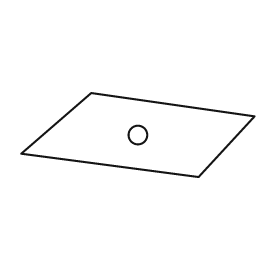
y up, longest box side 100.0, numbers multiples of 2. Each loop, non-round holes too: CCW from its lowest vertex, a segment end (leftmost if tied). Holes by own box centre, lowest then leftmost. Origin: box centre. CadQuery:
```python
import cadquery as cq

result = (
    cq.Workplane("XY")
    .moveTo(26.0, -18.0)
    .lineTo(50.0, 8.0)
    .lineTo(-20.0, 18.0)
    .lineTo(-50.0, -8.0)
    .close()
    .moveTo(0.0, 0.0)
    .circle(4.0)
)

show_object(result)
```